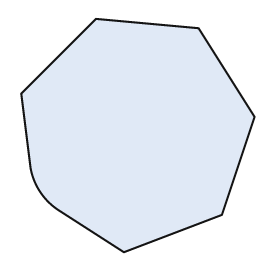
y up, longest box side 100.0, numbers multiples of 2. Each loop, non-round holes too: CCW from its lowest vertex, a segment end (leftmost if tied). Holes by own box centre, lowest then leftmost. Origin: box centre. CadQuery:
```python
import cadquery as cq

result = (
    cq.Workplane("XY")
    .moveTo(-6.0, -50.0)
    .lineTo(36.0, -34.0)
    .lineTo(50.0, 8.0)
    .lineTo(26.0, 46.0)
    .lineTo(-18.0, 50.0)
    .lineTo(-50.0, 18.0)
    .lineTo(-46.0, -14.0)
    .threePointArc((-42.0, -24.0), (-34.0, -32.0))
    .close()
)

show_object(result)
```